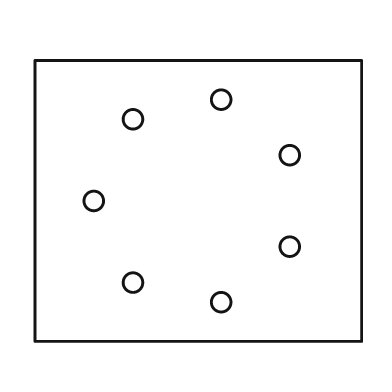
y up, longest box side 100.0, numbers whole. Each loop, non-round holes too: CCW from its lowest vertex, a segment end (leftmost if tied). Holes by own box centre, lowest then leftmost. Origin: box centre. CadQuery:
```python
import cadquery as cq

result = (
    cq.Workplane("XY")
    .moveTo(-50.0, -43.0)
    .lineTo(50.0, -43.0)
    .lineTo(50.0, 43.0)
    .lineTo(-50.0, 43.0)
    .close()
    .moveTo(7.0, -31.0)
    .circle(3.0)
    .moveTo(-20.0, -25.0)
    .circle(3.0)
    .moveTo(28.0, -14.0)
    .circle(3.0)
    .moveTo(-32.0, 0.0)
    .circle(3.0)
    .moveTo(28.0, 14.0)
    .circle(3.0)
    .moveTo(-20.0, 25.0)
    .circle(3.0)
    .moveTo(7.0, 31.0)
    .circle(3.0)
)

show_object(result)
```